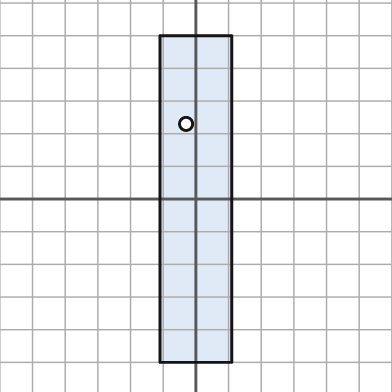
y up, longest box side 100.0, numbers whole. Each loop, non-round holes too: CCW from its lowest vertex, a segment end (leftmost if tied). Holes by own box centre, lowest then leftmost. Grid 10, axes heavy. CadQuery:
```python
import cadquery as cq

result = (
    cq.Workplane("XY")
    .moveTo(-11.0, -50.0)
    .lineTo(11.0, -50.0)
    .lineTo(11.0, 50.0)
    .lineTo(-11.0, 50.0)
    .close()
    .moveTo(-3.0, 23.0)
    .circle(2.0)
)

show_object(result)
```